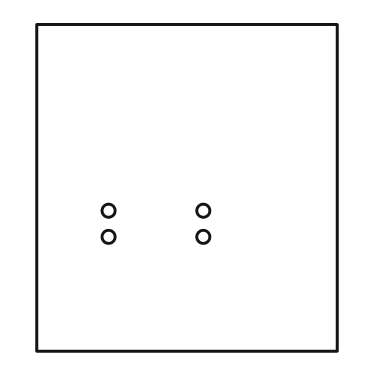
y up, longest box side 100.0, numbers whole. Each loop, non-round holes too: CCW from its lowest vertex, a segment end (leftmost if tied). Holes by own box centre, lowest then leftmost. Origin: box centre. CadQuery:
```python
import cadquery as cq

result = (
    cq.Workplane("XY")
    .moveTo(-46.0, -50.0)
    .lineTo(46.0, -50.0)
    .lineTo(46.0, 50.0)
    .lineTo(-46.0, 50.0)
    .close()
    .moveTo(-24.0, -15.0)
    .circle(2.0)
    .moveTo(5.0, -15.0)
    .circle(2.0)
    .moveTo(-24.0, -7.0)
    .circle(2.0)
    .moveTo(5.0, -7.0)
    .circle(2.0)
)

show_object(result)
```